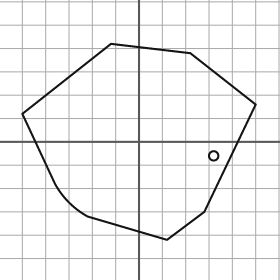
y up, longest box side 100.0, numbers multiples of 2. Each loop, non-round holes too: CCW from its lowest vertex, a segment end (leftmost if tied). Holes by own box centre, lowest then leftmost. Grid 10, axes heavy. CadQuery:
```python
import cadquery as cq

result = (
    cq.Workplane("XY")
    .moveTo(12.0, -42.0)
    .lineTo(28.0, -30.0)
    .lineTo(50.0, 16.0)
    .lineTo(22.0, 38.0)
    .lineTo(-12.0, 42.0)
    .lineTo(-50.0, 12.0)
    .lineTo(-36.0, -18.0)
    .threePointArc((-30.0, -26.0), (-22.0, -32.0))
    .close()
    .moveTo(32.0, -6.0)
    .circle(2.0)
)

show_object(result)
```